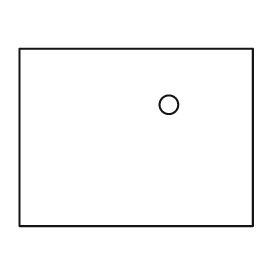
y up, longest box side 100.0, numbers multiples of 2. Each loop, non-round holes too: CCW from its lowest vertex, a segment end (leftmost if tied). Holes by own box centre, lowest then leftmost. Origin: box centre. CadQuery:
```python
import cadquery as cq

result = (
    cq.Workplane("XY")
    .moveTo(-50.0, -38.0)
    .lineTo(50.0, -38.0)
    .lineTo(50.0, 38.0)
    .lineTo(-50.0, 38.0)
    .close()
    .moveTo(14.0, 14.0)
    .circle(4.0)
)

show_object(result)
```